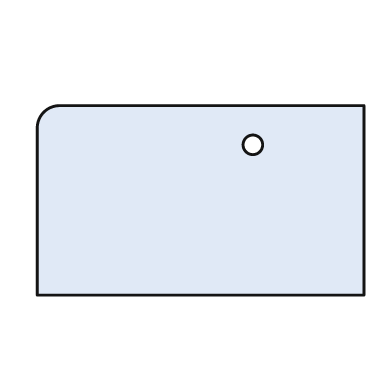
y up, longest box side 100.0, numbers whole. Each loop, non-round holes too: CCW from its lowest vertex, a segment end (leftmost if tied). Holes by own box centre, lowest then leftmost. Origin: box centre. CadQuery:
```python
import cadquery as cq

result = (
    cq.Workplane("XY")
    .moveTo(-50.0, -29.0)
    .lineTo(50.0, -29.0)
    .lineTo(50.0, 29.0)
    .lineTo(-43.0, 29.0)
    .threePointArc((-48.0, 27.0), (-50.0, 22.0))
    .close()
    .moveTo(16.0, 17.0)
    .circle(3.0)
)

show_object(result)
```